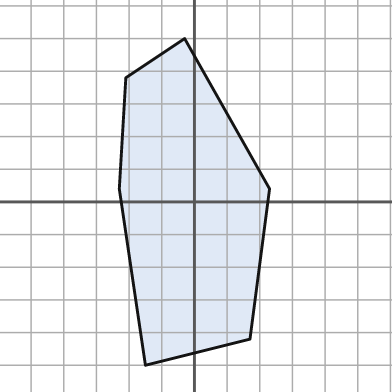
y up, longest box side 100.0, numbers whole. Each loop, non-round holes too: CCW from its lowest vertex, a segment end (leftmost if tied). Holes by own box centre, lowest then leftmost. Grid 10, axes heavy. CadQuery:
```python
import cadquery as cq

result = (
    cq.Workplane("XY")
    .moveTo(-15.0, -50.0)
    .lineTo(17.0, -42.0)
    .lineTo(23.0, 4.0)
    .lineTo(-3.0, 50.0)
    .lineTo(-21.0, 38.0)
    .lineTo(-23.0, 4.0)
    .close()
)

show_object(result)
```